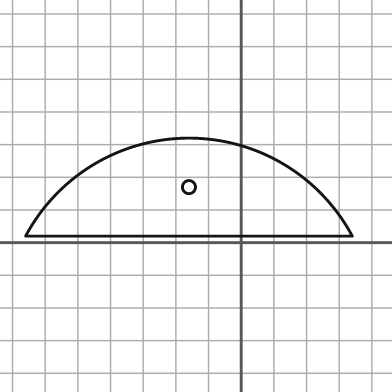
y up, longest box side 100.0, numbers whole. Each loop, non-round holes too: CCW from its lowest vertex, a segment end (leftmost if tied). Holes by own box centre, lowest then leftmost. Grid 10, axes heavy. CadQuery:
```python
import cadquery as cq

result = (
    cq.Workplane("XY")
    .moveTo(-66.0, 2.0)
    .lineTo(34.0, 2.0)
    .threePointArc((-16.0, 32.0), (-66.0, 2.0))
    .close()
    .moveTo(-16.0, 17.0)
    .circle(2.0)
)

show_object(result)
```